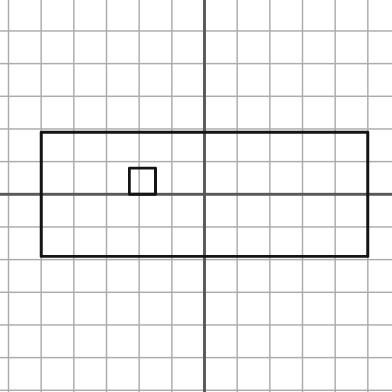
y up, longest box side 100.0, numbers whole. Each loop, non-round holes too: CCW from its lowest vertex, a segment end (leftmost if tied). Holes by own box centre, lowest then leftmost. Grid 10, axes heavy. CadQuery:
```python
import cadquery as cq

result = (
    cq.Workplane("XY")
    .moveTo(-50.0, -19.0)
    .lineTo(50.0, -19.0)
    .lineTo(50.0, 19.0)
    .lineTo(-50.0, 19.0)
    .close()
    .moveTo(-23.0, 0.0)
    .lineTo(-15.0, 0.0)
    .lineTo(-15.0, 8.0)
    .lineTo(-23.0, 8.0)
    .close()
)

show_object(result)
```